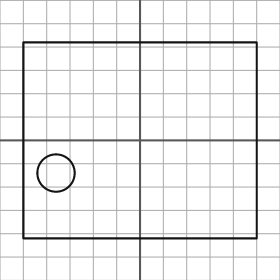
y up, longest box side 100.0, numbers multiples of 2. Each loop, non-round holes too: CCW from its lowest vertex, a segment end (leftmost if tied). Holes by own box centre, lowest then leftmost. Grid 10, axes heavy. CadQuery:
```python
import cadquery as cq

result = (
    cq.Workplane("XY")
    .moveTo(-50.0, -42.0)
    .lineTo(50.0, -42.0)
    .lineTo(50.0, 42.0)
    .lineTo(-50.0, 42.0)
    .close()
    .moveTo(-36.0, -14.0)
    .circle(8.0)
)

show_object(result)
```